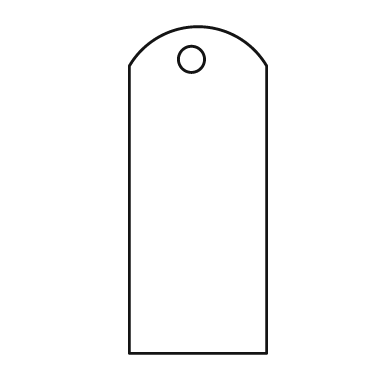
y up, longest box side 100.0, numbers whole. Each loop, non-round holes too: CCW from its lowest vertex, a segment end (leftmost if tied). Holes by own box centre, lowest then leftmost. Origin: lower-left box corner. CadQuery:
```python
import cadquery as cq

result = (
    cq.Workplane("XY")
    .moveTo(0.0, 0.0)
    .lineTo(42.0, 0.0)
    .lineTo(42.0, 88.0)
    .threePointArc((21.0, 100.0), (0.0, 88.0))
    .close()
    .moveTo(19.0, 90.0)
    .circle(4.0)
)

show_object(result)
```